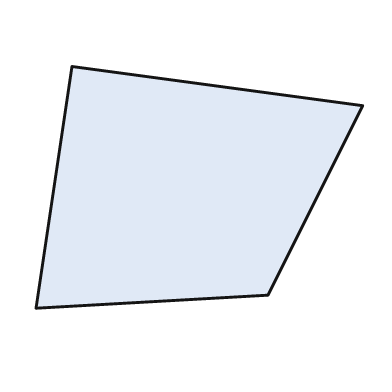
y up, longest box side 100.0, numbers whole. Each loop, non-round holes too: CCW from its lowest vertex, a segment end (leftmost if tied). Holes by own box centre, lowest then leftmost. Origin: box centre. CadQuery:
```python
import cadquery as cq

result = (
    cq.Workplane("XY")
    .moveTo(-50.0, -37.0)
    .lineTo(21.0, -33.0)
    .lineTo(50.0, 25.0)
    .lineTo(-39.0, 37.0)
    .close()
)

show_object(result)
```